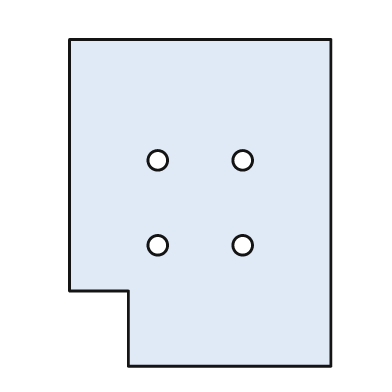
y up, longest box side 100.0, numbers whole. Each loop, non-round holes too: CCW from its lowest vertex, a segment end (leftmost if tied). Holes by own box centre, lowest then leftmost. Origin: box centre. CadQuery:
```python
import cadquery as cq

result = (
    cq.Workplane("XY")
    .moveTo(-22.0, -50.0)
    .lineTo(40.0, -50.0)
    .lineTo(40.0, 50.0)
    .lineTo(-40.0, 50.0)
    .lineTo(-40.0, -27.0)
    .lineTo(-22.0, -27.0)
    .close()
    .moveTo(-13.0, -13.0)
    .circle(3.0)
    .moveTo(13.0, -13.0)
    .circle(3.0)
    .moveTo(-13.0, 13.0)
    .circle(3.0)
    .moveTo(13.0, 13.0)
    .circle(3.0)
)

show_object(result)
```